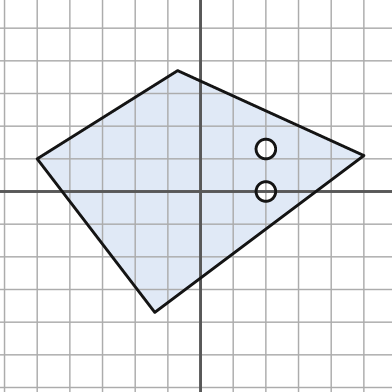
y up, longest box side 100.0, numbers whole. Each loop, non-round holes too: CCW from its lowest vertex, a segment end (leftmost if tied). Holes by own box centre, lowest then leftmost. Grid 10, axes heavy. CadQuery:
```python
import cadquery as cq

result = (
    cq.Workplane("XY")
    .moveTo(-14.0, -37.0)
    .lineTo(50.0, 11.0)
    .lineTo(-7.0, 37.0)
    .lineTo(-50.0, 10.0)
    .close()
    .moveTo(20.0, 0.0)
    .circle(3.0)
    .moveTo(20.0, 13.0)
    .circle(3.0)
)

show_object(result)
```